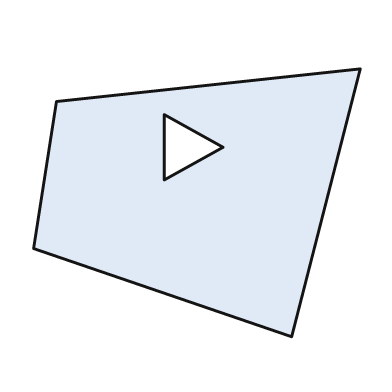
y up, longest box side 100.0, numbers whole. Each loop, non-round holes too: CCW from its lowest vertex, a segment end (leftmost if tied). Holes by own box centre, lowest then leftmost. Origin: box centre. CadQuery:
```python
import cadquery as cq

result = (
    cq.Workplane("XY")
    .moveTo(29.0, -41.0)
    .lineTo(50.0, 41.0)
    .lineTo(-43.0, 31.0)
    .lineTo(-50.0, -14.0)
    .close()
    .moveTo(-10.0, 7.0)
    .lineTo(8.0, 17.0)
    .lineTo(-10.0, 27.0)
    .close()
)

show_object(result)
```